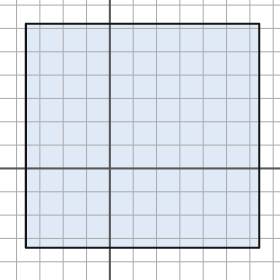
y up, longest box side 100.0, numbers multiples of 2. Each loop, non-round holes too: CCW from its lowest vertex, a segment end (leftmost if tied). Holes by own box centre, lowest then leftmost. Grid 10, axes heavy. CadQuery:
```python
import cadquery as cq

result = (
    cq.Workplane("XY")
    .moveTo(-36.0, -34.0)
    .lineTo(64.0, -34.0)
    .lineTo(64.0, 62.0)
    .lineTo(-36.0, 62.0)
    .close()
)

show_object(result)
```